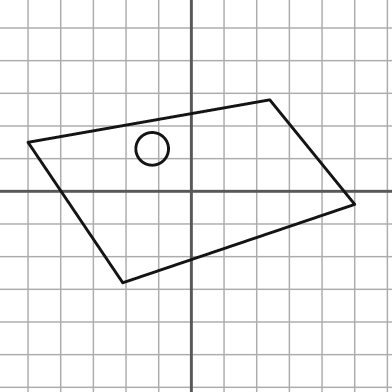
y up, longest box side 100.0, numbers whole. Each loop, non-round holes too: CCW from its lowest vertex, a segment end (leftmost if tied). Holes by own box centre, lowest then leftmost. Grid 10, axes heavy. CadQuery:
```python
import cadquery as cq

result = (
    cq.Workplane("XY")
    .moveTo(-21.0, -28.0)
    .lineTo(50.0, -4.0)
    .lineTo(24.0, 28.0)
    .lineTo(-50.0, 15.0)
    .close()
    .moveTo(-12.0, 13.0)
    .circle(5.0)
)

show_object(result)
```